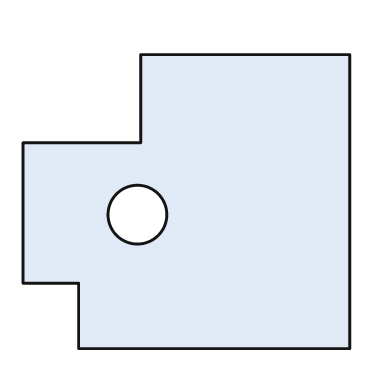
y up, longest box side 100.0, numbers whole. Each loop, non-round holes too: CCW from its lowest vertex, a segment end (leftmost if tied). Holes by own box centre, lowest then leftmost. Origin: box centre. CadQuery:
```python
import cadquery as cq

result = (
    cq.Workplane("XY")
    .moveTo(-33.0, -45.0)
    .lineTo(50.0, -45.0)
    .lineTo(50.0, 45.0)
    .lineTo(-14.0, 45.0)
    .lineTo(-14.0, 18.0)
    .lineTo(-50.0, 18.0)
    .lineTo(-50.0, -25.0)
    .lineTo(-33.0, -25.0)
    .close()
    .moveTo(-15.0, -4.0)
    .circle(9.0)
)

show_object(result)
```